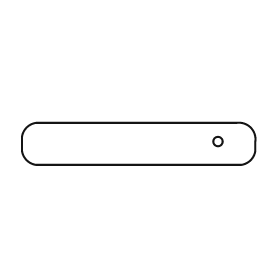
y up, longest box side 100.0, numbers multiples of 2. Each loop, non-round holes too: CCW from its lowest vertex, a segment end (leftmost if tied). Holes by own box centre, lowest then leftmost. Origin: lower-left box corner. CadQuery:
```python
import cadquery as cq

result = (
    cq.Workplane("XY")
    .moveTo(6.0, 0.0)
    .lineTo(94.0, 0.0)
    .threePointArc((98.0, 2.0), (100.0, 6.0))
    .lineTo(100.0, 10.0)
    .threePointArc((98.0, 16.0), (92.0, 18.0))
    .lineTo(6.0, 18.0)
    .threePointArc((2.0, 16.0), (0.0, 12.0))
    .lineTo(0.0, 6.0)
    .threePointArc((2.0, 2.0), (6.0, 0.0))
    .close()
    .moveTo(84.0, 10.0)
    .circle(2.0)
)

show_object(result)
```